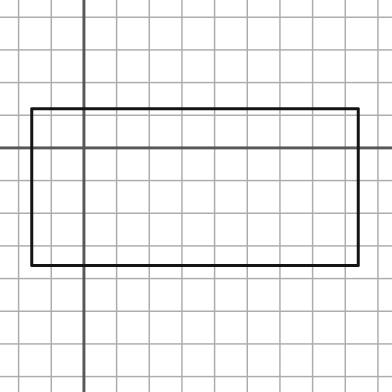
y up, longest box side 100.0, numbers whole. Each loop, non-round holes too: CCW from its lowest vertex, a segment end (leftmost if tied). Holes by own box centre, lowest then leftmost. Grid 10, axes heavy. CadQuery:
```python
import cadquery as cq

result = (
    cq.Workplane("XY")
    .moveTo(-16.0, -36.0)
    .lineTo(84.0, -36.0)
    .lineTo(84.0, 12.0)
    .lineTo(-16.0, 12.0)
    .close()
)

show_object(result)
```